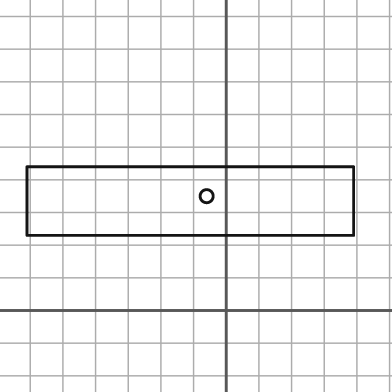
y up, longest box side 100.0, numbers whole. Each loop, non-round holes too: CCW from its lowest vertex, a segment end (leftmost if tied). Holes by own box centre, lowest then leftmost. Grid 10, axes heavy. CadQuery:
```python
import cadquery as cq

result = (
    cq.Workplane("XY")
    .moveTo(-61.0, 23.0)
    .lineTo(39.0, 23.0)
    .lineTo(39.0, 44.0)
    .lineTo(-61.0, 44.0)
    .close()
    .moveTo(-6.0, 35.0)
    .circle(2.0)
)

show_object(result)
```